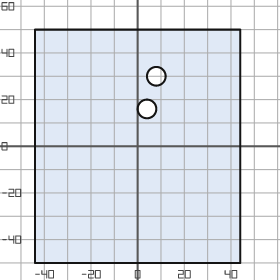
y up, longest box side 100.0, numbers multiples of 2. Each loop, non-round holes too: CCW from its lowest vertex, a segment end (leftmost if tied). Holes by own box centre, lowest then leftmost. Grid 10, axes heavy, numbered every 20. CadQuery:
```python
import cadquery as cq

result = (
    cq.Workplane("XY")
    .moveTo(-44.0, -50.0)
    .lineTo(44.0, -50.0)
    .lineTo(44.0, 50.0)
    .lineTo(-44.0, 50.0)
    .close()
    .moveTo(4.0, 16.0)
    .circle(4.0)
    .moveTo(8.0, 30.0)
    .circle(4.0)
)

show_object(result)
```